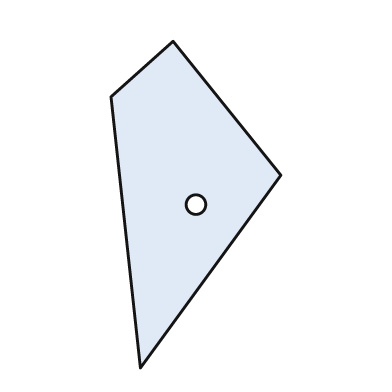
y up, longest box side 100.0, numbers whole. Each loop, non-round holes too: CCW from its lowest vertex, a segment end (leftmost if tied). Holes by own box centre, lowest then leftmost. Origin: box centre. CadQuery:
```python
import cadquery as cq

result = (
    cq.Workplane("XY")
    .moveTo(-17.0, -50.0)
    .lineTo(26.0, 9.0)
    .lineTo(-7.0, 50.0)
    .lineTo(-26.0, 33.0)
    .close()
    .moveTo(0.0, 0.0)
    .circle(3.0)
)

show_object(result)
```